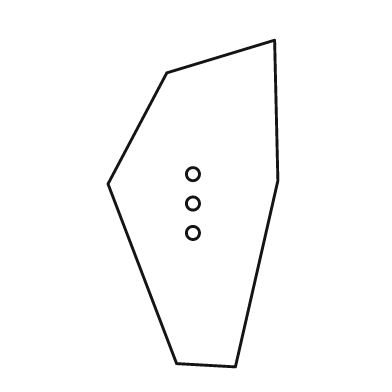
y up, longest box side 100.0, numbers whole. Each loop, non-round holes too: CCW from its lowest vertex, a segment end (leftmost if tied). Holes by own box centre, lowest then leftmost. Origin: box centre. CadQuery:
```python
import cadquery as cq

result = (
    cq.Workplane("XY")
    .moveTo(13.0, -50.0)
    .lineTo(26.0, 7.0)
    .lineTo(25.0, 50.0)
    .lineTo(-8.0, 40.0)
    .lineTo(-26.0, 6.0)
    .lineTo(-5.0, -49.0)
    .close()
    .moveTo(0.0, -9.0)
    .circle(2.0)
    .moveTo(0.0, 0.0)
    .circle(2.0)
    .moveTo(0.0, 9.0)
    .circle(2.0)
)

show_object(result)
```